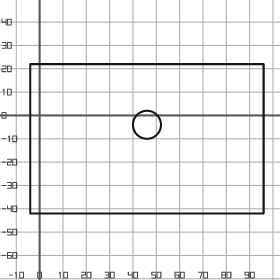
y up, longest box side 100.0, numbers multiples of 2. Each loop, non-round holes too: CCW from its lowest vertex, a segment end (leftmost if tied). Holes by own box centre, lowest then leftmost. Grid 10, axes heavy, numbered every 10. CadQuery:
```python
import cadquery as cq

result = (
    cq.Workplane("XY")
    .moveTo(-4.0, -42.0)
    .lineTo(96.0, -42.0)
    .lineTo(96.0, 22.0)
    .lineTo(-4.0, 22.0)
    .close()
    .moveTo(46.0, -4.0)
    .circle(6.0)
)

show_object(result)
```